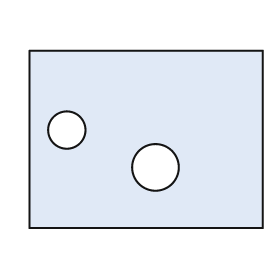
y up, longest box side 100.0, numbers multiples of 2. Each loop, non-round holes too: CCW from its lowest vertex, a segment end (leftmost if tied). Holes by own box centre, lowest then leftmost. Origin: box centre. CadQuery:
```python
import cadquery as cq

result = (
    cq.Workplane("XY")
    .moveTo(-50.0, -38.0)
    .lineTo(50.0, -38.0)
    .lineTo(50.0, 38.0)
    .lineTo(-50.0, 38.0)
    .close()
    .moveTo(4.0, -12.0)
    .circle(10.0)
    .moveTo(-34.0, 4.0)
    .circle(8.0)
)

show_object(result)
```